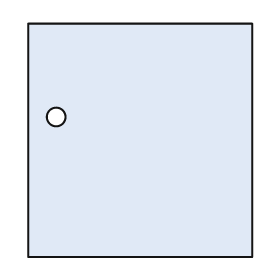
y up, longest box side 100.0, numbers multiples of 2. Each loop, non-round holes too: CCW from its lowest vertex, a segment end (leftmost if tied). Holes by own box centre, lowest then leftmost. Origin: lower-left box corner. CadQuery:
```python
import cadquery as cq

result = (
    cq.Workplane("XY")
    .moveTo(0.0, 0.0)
    .lineTo(96.0, 0.0)
    .lineTo(96.0, 100.0)
    .lineTo(0.0, 100.0)
    .close()
    .moveTo(12.0, 60.0)
    .circle(4.0)
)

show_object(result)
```